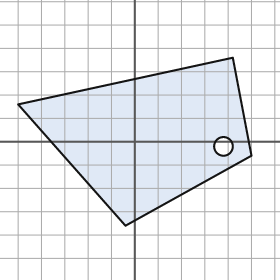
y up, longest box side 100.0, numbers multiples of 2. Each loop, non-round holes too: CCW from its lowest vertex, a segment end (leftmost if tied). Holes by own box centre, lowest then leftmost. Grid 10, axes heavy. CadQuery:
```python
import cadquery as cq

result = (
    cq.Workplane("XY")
    .moveTo(-4.0, -36.0)
    .lineTo(50.0, -6.0)
    .lineTo(42.0, 36.0)
    .lineTo(-50.0, 16.0)
    .close()
    .moveTo(38.0, -2.0)
    .circle(4.0)
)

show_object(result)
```